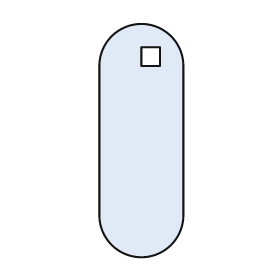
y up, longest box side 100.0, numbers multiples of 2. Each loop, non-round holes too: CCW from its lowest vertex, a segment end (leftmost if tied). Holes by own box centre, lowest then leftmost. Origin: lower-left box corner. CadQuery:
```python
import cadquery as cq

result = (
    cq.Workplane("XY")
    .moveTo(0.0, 18.0)
    .threePointArc((18.0, 0.0), (36.0, 18.0))
    .lineTo(36.0, 82.0)
    .threePointArc((18.0, 100.0), (0.0, 82.0))
    .close()
    .moveTo(18.0, 82.0)
    .lineTo(26.0, 82.0)
    .lineTo(26.0, 90.0)
    .lineTo(18.0, 90.0)
    .close()
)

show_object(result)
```